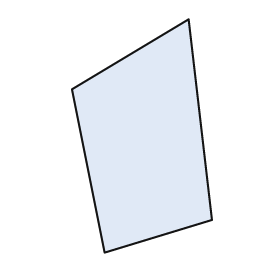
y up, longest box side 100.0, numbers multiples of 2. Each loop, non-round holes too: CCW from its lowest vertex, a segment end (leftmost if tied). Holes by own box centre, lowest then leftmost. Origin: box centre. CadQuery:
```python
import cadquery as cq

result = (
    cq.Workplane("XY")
    .moveTo(-16.0, -50.0)
    .lineTo(30.0, -36.0)
    .lineTo(20.0, 50.0)
    .lineTo(-30.0, 20.0)
    .close()
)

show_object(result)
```